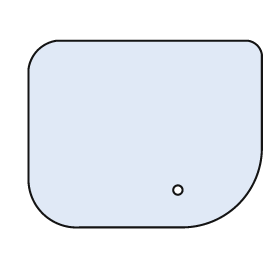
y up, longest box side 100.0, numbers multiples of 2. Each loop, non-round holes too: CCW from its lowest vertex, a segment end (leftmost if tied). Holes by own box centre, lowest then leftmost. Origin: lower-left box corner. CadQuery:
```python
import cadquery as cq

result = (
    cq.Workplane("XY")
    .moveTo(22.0, 0.0)
    .lineTo(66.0, 0.0)
    .threePointArc((90.0, 10.0), (100.0, 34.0))
    .lineTo(100.0, 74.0)
    .threePointArc((98.0, 78.0), (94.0, 80.0))
    .lineTo(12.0, 80.0)
    .threePointArc((4.0, 76.0), (0.0, 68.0))
    .lineTo(0.0, 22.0)
    .threePointArc((6.0, 6.0), (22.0, 0.0))
    .close()
    .moveTo(64.0, 16.0)
    .circle(2.0)
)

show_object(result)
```